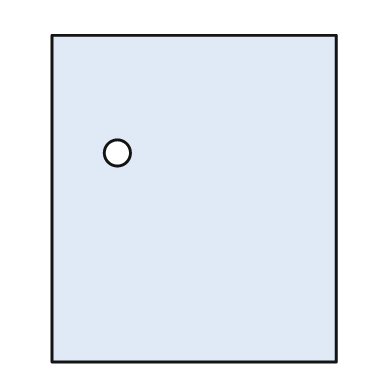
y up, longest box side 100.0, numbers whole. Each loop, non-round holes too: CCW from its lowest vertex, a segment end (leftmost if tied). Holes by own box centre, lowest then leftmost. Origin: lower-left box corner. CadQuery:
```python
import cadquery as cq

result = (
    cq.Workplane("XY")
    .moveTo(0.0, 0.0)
    .lineTo(87.0, 0.0)
    .lineTo(87.0, 100.0)
    .lineTo(0.0, 100.0)
    .close()
    .moveTo(20.0, 64.0)
    .circle(4.0)
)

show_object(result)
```